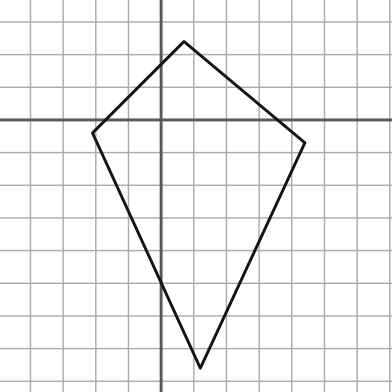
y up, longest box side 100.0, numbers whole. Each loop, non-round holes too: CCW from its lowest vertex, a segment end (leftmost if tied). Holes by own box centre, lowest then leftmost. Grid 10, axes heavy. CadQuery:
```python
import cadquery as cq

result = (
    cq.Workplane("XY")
    .moveTo(12.0, -76.0)
    .lineTo(44.0, -7.0)
    .lineTo(7.0, 24.0)
    .lineTo(-21.0, -4.0)
    .close()
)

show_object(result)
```